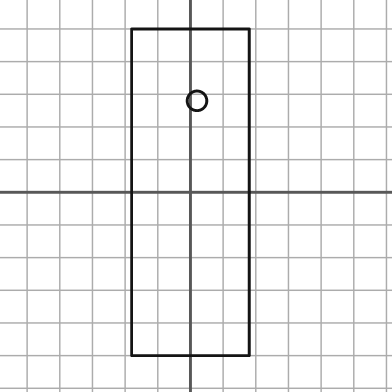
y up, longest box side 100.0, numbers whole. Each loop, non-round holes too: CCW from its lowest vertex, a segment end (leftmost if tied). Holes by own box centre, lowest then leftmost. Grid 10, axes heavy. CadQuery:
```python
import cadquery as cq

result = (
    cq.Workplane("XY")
    .moveTo(-18.0, -50.0)
    .lineTo(18.0, -50.0)
    .lineTo(18.0, 50.0)
    .lineTo(-18.0, 50.0)
    .close()
    .moveTo(2.0, 28.0)
    .circle(3.0)
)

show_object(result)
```